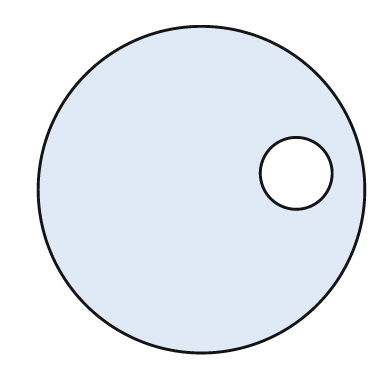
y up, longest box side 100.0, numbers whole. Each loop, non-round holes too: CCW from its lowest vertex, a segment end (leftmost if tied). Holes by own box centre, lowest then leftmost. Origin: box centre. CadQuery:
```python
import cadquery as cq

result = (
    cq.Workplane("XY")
    .moveTo(0.0, 0.0)
    .circle(50.0)
    .moveTo(29.0, 5.0)
    .circle(11.0)
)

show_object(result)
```